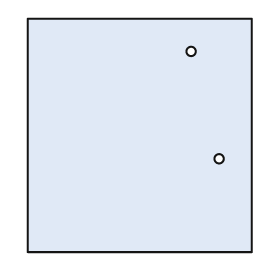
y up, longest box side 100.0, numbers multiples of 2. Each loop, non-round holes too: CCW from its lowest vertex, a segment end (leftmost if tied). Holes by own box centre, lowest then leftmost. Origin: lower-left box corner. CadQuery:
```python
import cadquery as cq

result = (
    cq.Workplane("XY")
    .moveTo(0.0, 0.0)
    .lineTo(96.0, 0.0)
    .lineTo(96.0, 100.0)
    .lineTo(0.0, 100.0)
    .close()
    .moveTo(82.0, 40.0)
    .circle(2.0)
    .moveTo(70.0, 86.0)
    .circle(2.0)
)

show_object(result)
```